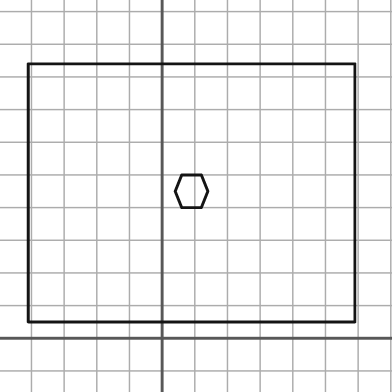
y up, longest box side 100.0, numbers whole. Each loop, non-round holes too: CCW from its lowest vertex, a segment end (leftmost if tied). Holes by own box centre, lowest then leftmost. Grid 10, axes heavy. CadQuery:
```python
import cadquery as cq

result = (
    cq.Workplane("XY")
    .moveTo(-41.0, 5.0)
    .lineTo(59.0, 5.0)
    .lineTo(59.0, 84.0)
    .lineTo(-41.0, 84.0)
    .close()
    .moveTo(6.0, 40.0)
    .lineTo(12.0, 40.0)
    .lineTo(14.0, 45.0)
    .lineTo(12.0, 50.0)
    .lineTo(6.0, 50.0)
    .lineTo(4.0, 45.0)
    .close()
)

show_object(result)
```